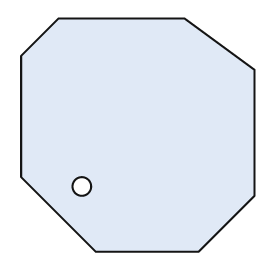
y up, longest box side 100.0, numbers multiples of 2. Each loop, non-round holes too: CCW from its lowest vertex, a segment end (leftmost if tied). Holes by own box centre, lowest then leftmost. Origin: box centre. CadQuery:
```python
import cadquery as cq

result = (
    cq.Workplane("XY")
    .moveTo(-18.0, -50.0)
    .lineTo(26.0, -50.0)
    .lineTo(50.0, -26.0)
    .lineTo(50.0, 28.0)
    .lineTo(20.0, 50.0)
    .lineTo(-34.0, 50.0)
    .lineTo(-50.0, 34.0)
    .lineTo(-50.0, -18.0)
    .close()
    .moveTo(-24.0, -22.0)
    .circle(4.0)
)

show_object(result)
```